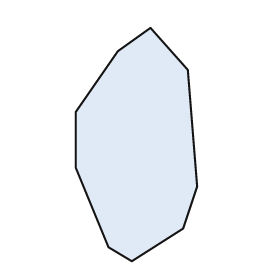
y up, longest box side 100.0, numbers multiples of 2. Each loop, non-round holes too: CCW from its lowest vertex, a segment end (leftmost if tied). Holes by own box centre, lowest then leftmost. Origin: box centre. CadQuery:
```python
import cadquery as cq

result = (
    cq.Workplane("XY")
    .moveTo(-2.0, -50.0)
    .lineTo(20.0, -36.0)
    .lineTo(26.0, -18.0)
    .lineTo(22.0, 32.0)
    .lineTo(6.0, 50.0)
    .lineTo(-8.0, 40.0)
    .lineTo(-26.0, 14.0)
    .lineTo(-26.0, -10.0)
    .lineTo(-12.0, -44.0)
    .close()
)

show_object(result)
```